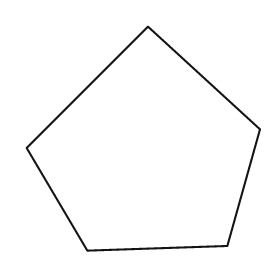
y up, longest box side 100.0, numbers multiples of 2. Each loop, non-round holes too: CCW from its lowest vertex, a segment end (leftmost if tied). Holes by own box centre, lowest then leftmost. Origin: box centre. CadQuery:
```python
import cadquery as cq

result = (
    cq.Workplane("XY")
    .moveTo(-24.0, -48.0)
    .lineTo(36.0, -46.0)
    .lineTo(50.0, 4.0)
    .lineTo(2.0, 48.0)
    .lineTo(-50.0, -4.0)
    .close()
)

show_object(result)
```